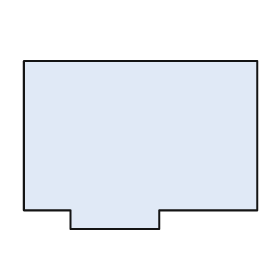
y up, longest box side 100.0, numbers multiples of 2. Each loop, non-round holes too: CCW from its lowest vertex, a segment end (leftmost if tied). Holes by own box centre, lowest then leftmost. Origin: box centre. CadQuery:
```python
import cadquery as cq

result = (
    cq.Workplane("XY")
    .moveTo(-30.0, -36.0)
    .lineTo(8.0, -36.0)
    .lineTo(8.0, -28.0)
    .lineTo(50.0, -28.0)
    .lineTo(50.0, 36.0)
    .lineTo(-50.0, 36.0)
    .lineTo(-50.0, -28.0)
    .lineTo(-30.0, -28.0)
    .close()
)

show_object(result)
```